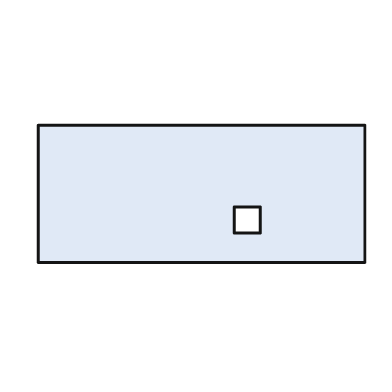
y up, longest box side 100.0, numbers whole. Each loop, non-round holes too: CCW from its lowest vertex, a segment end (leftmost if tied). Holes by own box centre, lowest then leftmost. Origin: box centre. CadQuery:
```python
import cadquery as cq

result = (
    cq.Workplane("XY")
    .moveTo(-50.0, -21.0)
    .lineTo(50.0, -21.0)
    .lineTo(50.0, 21.0)
    .lineTo(-50.0, 21.0)
    .close()
    .moveTo(10.0, -12.0)
    .lineTo(18.0, -12.0)
    .lineTo(18.0, -4.0)
    .lineTo(10.0, -4.0)
    .close()
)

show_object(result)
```